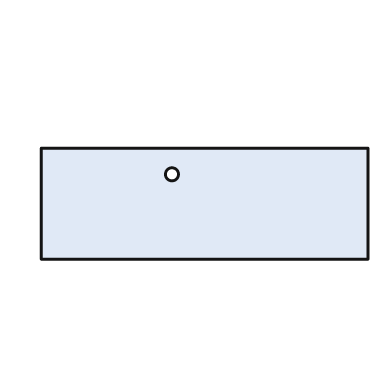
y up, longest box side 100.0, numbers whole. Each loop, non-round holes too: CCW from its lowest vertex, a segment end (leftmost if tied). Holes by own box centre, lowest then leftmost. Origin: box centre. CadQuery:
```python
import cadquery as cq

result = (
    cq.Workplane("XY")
    .moveTo(-50.0, -17.0)
    .lineTo(50.0, -17.0)
    .lineTo(50.0, 17.0)
    .lineTo(-50.0, 17.0)
    .close()
    .moveTo(-10.0, 9.0)
    .circle(2.0)
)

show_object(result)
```